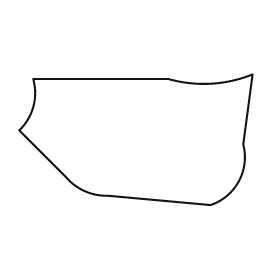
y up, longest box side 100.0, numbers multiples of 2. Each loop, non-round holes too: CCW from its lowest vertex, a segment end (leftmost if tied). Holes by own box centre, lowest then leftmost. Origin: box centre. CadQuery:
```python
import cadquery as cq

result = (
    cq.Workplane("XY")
    .moveTo(32.0, -28.0)
    .threePointArc((44.0, -18.0), (46.0, -2.0))
    .lineTo(50.0, 28.0)
    .threePointArc((32.0, 24.0), (14.0, 26.0))
    .lineTo(-44.0, 26.0)
    .threePointArc((-44.0, 14.0), (-50.0, 4.0))
    .lineTo(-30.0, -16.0)
    .threePointArc((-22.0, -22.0), (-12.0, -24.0))
    .close()
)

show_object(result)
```